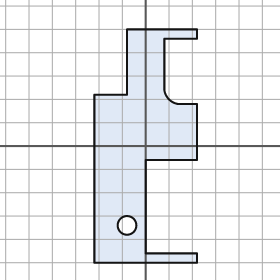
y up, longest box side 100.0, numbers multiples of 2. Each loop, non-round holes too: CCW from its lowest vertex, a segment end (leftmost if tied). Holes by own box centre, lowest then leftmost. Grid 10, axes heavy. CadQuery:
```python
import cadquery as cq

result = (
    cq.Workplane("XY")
    .moveTo(-22.0, -50.0)
    .lineTo(22.0, -50.0)
    .lineTo(22.0, -46.0)
    .lineTo(0.0, -46.0)
    .lineTo(0.0, -6.0)
    .lineTo(22.0, -6.0)
    .lineTo(22.0, 18.0)
    .lineTo(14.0, 18.0)
    .threePointArc((10.0, 20.0), (8.0, 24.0))
    .lineTo(8.0, 46.0)
    .lineTo(22.0, 46.0)
    .lineTo(22.0, 50.0)
    .lineTo(-8.0, 50.0)
    .lineTo(-8.0, 22.0)
    .lineTo(-22.0, 22.0)
    .close()
    .moveTo(-8.0, -34.0)
    .circle(4.0)
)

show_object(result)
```